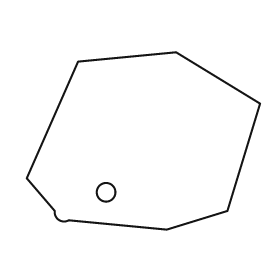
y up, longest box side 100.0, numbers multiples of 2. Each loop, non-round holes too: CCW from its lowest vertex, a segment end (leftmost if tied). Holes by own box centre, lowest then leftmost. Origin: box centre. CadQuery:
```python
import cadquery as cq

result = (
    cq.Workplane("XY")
    .moveTo(10.0, -38.0)
    .lineTo(36.0, -30.0)
    .lineTo(50.0, 16.0)
    .lineTo(14.0, 38.0)
    .lineTo(-28.0, 34.0)
    .lineTo(-50.0, -16.0)
    .lineTo(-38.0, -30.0)
    .threePointArc((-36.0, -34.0), (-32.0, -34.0))
    .close()
    .moveTo(-16.0, -22.0)
    .circle(4.0)
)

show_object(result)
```